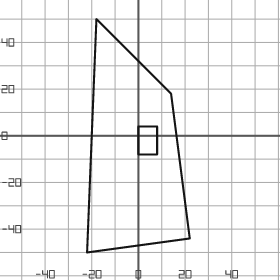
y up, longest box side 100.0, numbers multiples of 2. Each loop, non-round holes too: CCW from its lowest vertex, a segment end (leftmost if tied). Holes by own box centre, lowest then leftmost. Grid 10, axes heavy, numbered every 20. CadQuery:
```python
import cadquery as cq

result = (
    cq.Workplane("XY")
    .moveTo(-22.0, -50.0)
    .lineTo(22.0, -44.0)
    .lineTo(14.0, 18.0)
    .lineTo(-18.0, 50.0)
    .close()
    .moveTo(0.0, -8.0)
    .lineTo(8.0, -8.0)
    .lineTo(8.0, 4.0)
    .lineTo(0.0, 4.0)
    .close()
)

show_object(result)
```